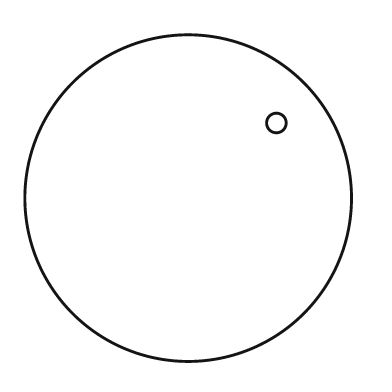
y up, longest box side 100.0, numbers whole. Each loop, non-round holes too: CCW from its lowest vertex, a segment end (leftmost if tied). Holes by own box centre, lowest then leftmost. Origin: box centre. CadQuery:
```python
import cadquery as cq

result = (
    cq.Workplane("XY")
    .moveTo(0.0, 0.0)
    .circle(50.0)
    .moveTo(27.0, 23.0)
    .circle(3.0)
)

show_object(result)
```